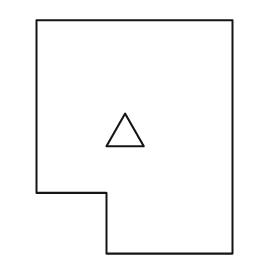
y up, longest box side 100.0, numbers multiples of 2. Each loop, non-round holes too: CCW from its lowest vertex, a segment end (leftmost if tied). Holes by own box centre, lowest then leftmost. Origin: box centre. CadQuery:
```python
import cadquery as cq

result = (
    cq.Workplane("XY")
    .moveTo(-12.0, -50.0)
    .lineTo(42.0, -50.0)
    .lineTo(42.0, 50.0)
    .lineTo(-42.0, 50.0)
    .lineTo(-42.0, -24.0)
    .lineTo(-12.0, -24.0)
    .close()
    .moveTo(-12.0, -4.0)
    .lineTo(4.0, -4.0)
    .lineTo(-4.0, 10.0)
    .close()
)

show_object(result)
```